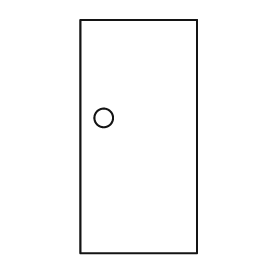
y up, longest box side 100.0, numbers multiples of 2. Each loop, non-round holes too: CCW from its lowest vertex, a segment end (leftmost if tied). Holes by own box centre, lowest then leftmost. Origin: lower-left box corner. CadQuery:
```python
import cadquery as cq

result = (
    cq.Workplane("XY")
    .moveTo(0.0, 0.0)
    .lineTo(50.0, 0.0)
    .lineTo(50.0, 100.0)
    .lineTo(0.0, 100.0)
    .close()
    .moveTo(10.0, 58.0)
    .circle(4.0)
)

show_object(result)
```